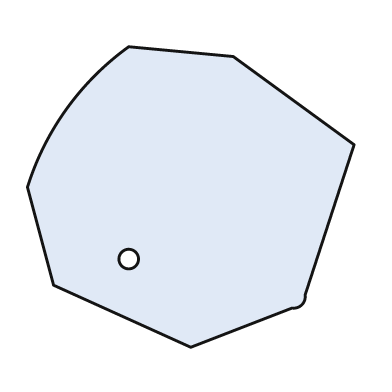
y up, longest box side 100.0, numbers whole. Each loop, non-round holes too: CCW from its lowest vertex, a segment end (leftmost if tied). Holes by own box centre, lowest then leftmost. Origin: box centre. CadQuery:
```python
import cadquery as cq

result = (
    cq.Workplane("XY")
    .moveTo(0.0, -46.0)
    .lineTo(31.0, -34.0)
    .threePointArc((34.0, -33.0), (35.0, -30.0))
    .lineTo(50.0, 16.0)
    .lineTo(13.0, 43.0)
    .lineTo(-19.0, 46.0)
    .threePointArc((-38.0, 27.0), (-50.0, 3.0))
    .lineTo(-42.0, -27.0)
    .close()
    .moveTo(-19.0, -19.0)
    .circle(3.0)
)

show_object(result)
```